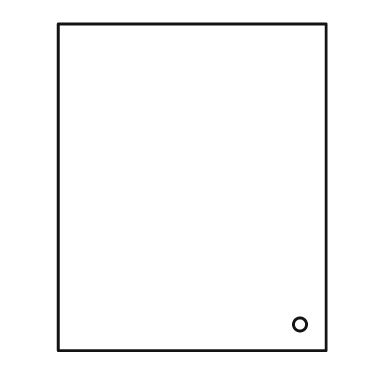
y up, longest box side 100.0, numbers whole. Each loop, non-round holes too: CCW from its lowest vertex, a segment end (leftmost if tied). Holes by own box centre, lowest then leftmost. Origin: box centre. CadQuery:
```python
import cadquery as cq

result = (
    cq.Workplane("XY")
    .moveTo(-41.0, -50.0)
    .lineTo(41.0, -50.0)
    .lineTo(41.0, 50.0)
    .lineTo(-41.0, 50.0)
    .close()
    .moveTo(33.0, -42.0)
    .circle(2.0)
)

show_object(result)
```